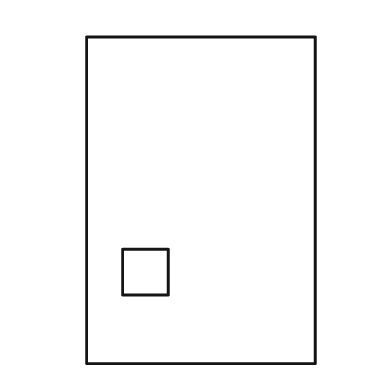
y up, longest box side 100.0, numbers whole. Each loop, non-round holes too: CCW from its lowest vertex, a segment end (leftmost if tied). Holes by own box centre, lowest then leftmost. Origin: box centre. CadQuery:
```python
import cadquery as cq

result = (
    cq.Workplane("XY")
    .moveTo(-35.0, -50.0)
    .lineTo(35.0, -50.0)
    .lineTo(35.0, 50.0)
    .lineTo(-35.0, 50.0)
    .close()
    .moveTo(-24.0, -29.0)
    .lineTo(-10.0, -29.0)
    .lineTo(-10.0, -15.0)
    .lineTo(-24.0, -15.0)
    .close()
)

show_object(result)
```